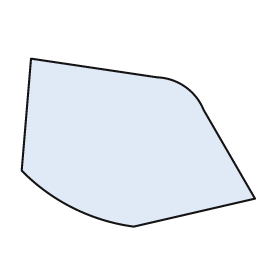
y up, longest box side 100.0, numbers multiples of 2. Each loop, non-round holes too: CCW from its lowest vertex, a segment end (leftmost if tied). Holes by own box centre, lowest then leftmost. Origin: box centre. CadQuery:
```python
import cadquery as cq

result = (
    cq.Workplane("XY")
    .moveTo(-2.0, -36.0)
    .lineTo(50.0, -24.0)
    .lineTo(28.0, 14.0)
    .threePointArc((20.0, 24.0), (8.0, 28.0))
    .lineTo(-46.0, 36.0)
    .lineTo(-50.0, -12.0)
    .threePointArc((-28.0, -28.0), (-2.0, -36.0))
    .close()
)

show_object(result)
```